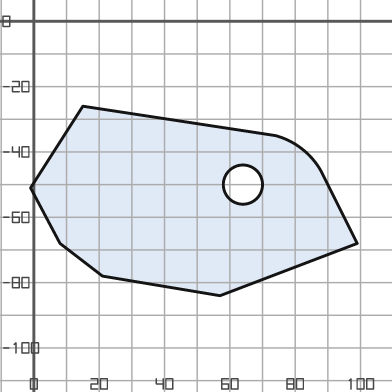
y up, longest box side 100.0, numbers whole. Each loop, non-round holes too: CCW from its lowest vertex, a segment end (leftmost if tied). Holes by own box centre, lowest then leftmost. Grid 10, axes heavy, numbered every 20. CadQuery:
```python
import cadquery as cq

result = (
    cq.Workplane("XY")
    .moveTo(57.0, -84.0)
    .lineTo(99.0, -68.0)
    .lineTo(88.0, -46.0)
    .threePointArc((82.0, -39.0), (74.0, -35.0))
    .lineTo(15.0, -26.0)
    .lineTo(-1.0, -51.0)
    .lineTo(8.0, -68.0)
    .lineTo(21.0, -78.0)
    .close()
    .moveTo(64.0, -50.0)
    .circle(6.0)
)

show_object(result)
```